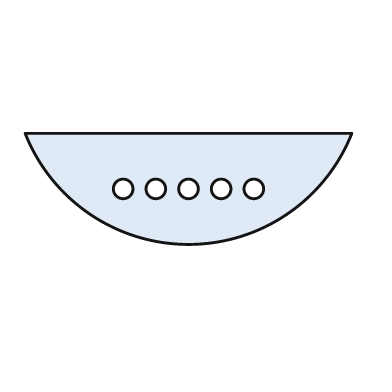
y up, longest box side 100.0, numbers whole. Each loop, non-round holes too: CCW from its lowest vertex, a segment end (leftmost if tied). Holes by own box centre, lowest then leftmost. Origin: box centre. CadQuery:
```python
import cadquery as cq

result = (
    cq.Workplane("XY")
    .moveTo(-50.0, 17.0)
    .threePointArc((0.0, -17.0), (50.0, 17.0))
    .close()
    .moveTo(-20.0, 0.0)
    .circle(3.0)
    .moveTo(-10.0, 0.0)
    .circle(3.0)
    .moveTo(0.0, 0.0)
    .circle(3.0)
    .moveTo(10.0, 0.0)
    .circle(3.0)
    .moveTo(20.0, 0.0)
    .circle(3.0)
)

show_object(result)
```